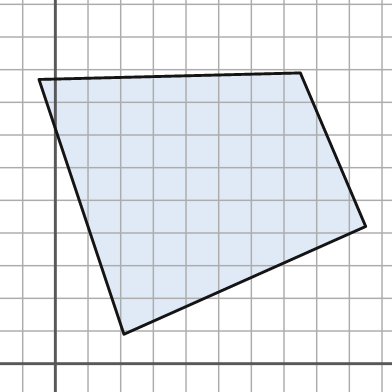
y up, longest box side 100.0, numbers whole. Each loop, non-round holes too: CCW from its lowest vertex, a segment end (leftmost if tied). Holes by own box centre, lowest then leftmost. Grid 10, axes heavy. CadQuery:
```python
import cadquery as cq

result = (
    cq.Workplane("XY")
    .moveTo(21.0, 9.0)
    .lineTo(95.0, 42.0)
    .lineTo(75.0, 89.0)
    .lineTo(-5.0, 87.0)
    .close()
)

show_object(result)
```